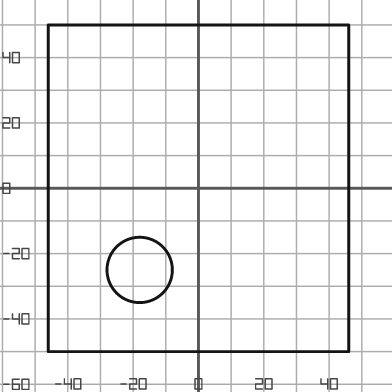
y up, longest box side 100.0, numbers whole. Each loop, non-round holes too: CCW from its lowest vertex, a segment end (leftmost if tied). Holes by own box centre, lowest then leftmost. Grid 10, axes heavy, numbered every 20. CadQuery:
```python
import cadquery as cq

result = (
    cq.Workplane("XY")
    .moveTo(-46.0, -50.0)
    .lineTo(46.0, -50.0)
    .lineTo(46.0, 50.0)
    .lineTo(-46.0, 50.0)
    .close()
    .moveTo(-18.0, -25.0)
    .circle(10.0)
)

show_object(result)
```